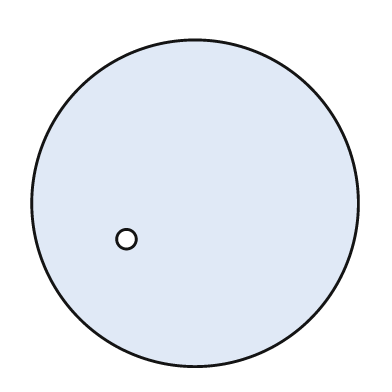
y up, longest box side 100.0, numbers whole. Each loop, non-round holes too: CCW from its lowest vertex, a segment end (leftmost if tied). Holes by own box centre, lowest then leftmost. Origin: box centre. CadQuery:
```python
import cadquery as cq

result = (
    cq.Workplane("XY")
    .moveTo(0.0, 0.0)
    .circle(50.0)
    .moveTo(-21.0, -11.0)
    .circle(3.0)
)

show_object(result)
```